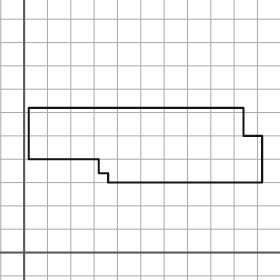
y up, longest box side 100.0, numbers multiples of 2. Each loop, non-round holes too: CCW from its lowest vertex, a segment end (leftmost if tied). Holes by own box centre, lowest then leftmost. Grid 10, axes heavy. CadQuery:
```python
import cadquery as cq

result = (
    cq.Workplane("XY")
    .moveTo(36.0, 30.0)
    .lineTo(102.0, 30.0)
    .lineTo(102.0, 50.0)
    .lineTo(94.0, 50.0)
    .lineTo(94.0, 62.0)
    .lineTo(2.0, 62.0)
    .lineTo(2.0, 40.0)
    .lineTo(32.0, 40.0)
    .lineTo(32.0, 34.0)
    .lineTo(36.0, 34.0)
    .close()
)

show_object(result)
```